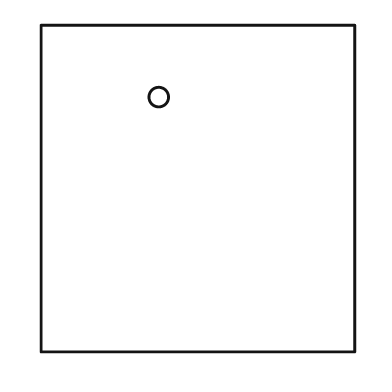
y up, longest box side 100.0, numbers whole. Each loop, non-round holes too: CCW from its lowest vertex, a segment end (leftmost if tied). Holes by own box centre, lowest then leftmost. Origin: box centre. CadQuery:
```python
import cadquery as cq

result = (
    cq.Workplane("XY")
    .moveTo(-48.0, -50.0)
    .lineTo(48.0, -50.0)
    .lineTo(48.0, 50.0)
    .lineTo(-48.0, 50.0)
    .close()
    .moveTo(-12.0, 28.0)
    .circle(3.0)
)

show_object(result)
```